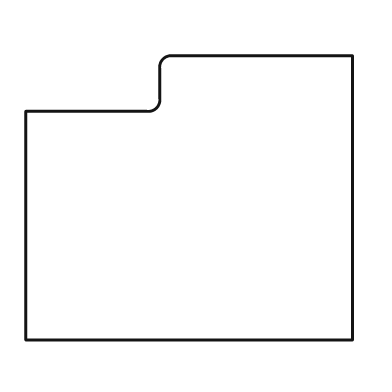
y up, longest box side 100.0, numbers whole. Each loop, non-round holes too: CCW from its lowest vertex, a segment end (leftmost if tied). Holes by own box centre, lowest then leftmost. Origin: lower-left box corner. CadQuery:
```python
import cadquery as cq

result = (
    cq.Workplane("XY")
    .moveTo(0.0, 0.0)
    .lineTo(100.0, 0.0)
    .lineTo(100.0, 87.0)
    .lineTo(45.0, 87.0)
    .threePointArc((42.0, 86.0), (41.0, 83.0))
    .lineTo(41.0, 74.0)
    .threePointArc((40.0, 71.0), (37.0, 70.0))
    .lineTo(0.0, 70.0)
    .close()
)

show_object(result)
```